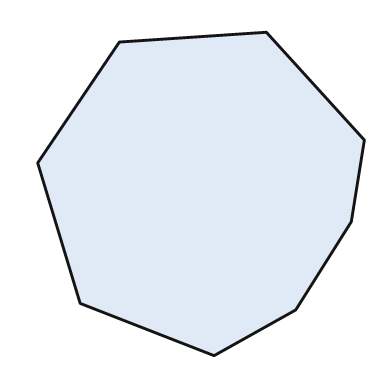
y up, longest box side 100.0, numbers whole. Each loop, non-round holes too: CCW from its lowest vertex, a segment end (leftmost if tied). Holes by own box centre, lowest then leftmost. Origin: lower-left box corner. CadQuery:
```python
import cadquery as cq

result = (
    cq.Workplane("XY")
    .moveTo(54.0, 0.0)
    .lineTo(79.0, 14.0)
    .lineTo(96.0, 41.0)
    .lineTo(100.0, 66.0)
    .lineTo(70.0, 99.0)
    .lineTo(25.0, 96.0)
    .lineTo(0.0, 59.0)
    .lineTo(13.0, 16.0)
    .close()
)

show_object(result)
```